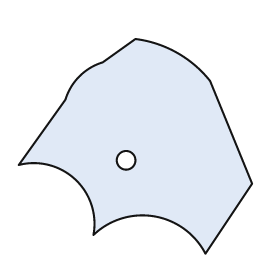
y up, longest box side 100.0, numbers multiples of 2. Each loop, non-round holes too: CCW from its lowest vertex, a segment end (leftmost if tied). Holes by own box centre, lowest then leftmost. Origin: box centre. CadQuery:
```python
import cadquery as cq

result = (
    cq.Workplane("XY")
    .moveTo(30.0, -46.0)
    .lineTo(50.0, -16.0)
    .lineTo(32.0, 28.0)
    .threePointArc((18.0, 40.0), (0.0, 46.0))
    .lineTo(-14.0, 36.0)
    .threePointArc((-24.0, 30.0), (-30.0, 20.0))
    .lineTo(-50.0, -8.0)
    .threePointArc((-26.0, -14.0), (-18.0, -38.0))
    .threePointArc((8.0, -30.0), (30.0, -46.0))
    .close()
    .moveTo(-4.0, -6.0)
    .circle(4.0)
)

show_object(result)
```